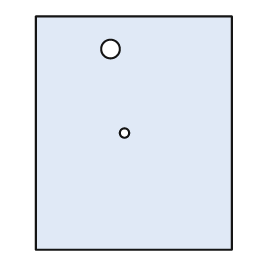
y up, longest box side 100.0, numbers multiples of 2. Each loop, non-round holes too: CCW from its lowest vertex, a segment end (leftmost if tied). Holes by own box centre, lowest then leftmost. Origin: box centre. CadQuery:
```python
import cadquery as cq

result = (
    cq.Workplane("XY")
    .moveTo(-42.0, -50.0)
    .lineTo(42.0, -50.0)
    .lineTo(42.0, 50.0)
    .lineTo(-42.0, 50.0)
    .close()
    .moveTo(-4.0, 0.0)
    .circle(2.0)
    .moveTo(-10.0, 36.0)
    .circle(4.0)
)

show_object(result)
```